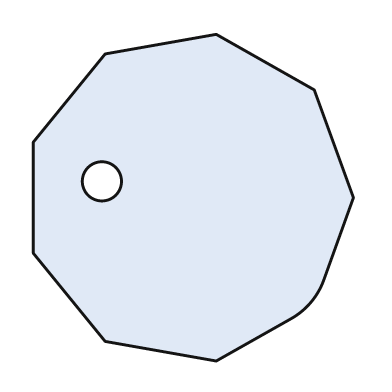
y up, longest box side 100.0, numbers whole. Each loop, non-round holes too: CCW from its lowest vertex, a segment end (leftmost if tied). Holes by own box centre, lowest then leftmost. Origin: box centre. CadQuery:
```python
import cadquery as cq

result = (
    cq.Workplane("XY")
    .moveTo(7.0, -50.0)
    .lineTo(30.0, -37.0)
    .threePointArc((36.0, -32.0), (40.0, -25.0))
    .lineTo(49.0, 0.0)
    .lineTo(37.0, 33.0)
    .lineTo(7.0, 50.0)
    .lineTo(-27.0, 44.0)
    .lineTo(-49.0, 17.0)
    .lineTo(-49.0, -17.0)
    .lineTo(-27.0, -44.0)
    .close()
    .moveTo(-28.0, 5.0)
    .circle(6.0)
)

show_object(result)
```